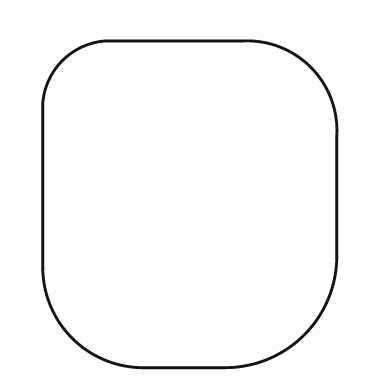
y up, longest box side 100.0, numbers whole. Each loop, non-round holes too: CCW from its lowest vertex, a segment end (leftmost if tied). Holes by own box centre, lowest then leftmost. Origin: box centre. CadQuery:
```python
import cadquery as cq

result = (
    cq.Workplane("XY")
    .moveTo(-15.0, -50.0)
    .lineTo(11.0, -50.0)
    .threePointArc((35.0, -40.0), (45.0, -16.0))
    .lineTo(45.0, 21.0)
    .threePointArc((37.0, 42.0), (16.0, 50.0))
    .lineTo(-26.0, 50.0)
    .threePointArc((-39.0, 44.0), (-45.0, 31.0))
    .lineTo(-45.0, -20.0)
    .threePointArc((-36.0, -41.0), (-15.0, -50.0))
    .close()
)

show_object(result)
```